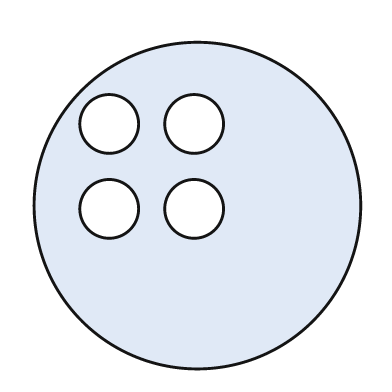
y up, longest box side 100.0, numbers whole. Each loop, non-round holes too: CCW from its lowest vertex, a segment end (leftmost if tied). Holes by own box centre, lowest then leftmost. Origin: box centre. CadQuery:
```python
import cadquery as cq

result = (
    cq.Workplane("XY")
    .moveTo(0.0, 0.0)
    .circle(50.0)
    .moveTo(-27.0, -1.0)
    .circle(9.0)
    .moveTo(-1.0, -1.0)
    .circle(9.0)
    .moveTo(-27.0, 25.0)
    .circle(9.0)
    .moveTo(-1.0, 25.0)
    .circle(9.0)
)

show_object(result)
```